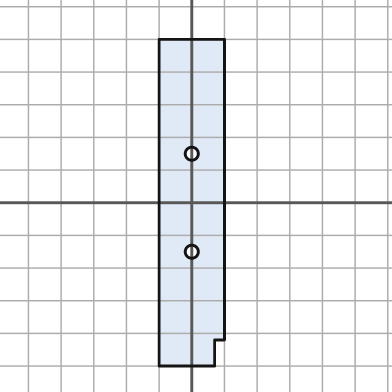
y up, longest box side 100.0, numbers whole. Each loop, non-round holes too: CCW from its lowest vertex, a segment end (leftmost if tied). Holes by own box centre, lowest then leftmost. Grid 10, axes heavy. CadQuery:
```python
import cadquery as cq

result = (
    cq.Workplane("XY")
    .moveTo(-10.0, -50.0)
    .lineTo(7.0, -50.0)
    .lineTo(7.0, -42.0)
    .lineTo(10.0, -42.0)
    .lineTo(10.0, 50.0)
    .lineTo(-10.0, 50.0)
    .close()
    .moveTo(0.0, -15.0)
    .circle(2.0)
    .moveTo(0.0, 15.0)
    .circle(2.0)
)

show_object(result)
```